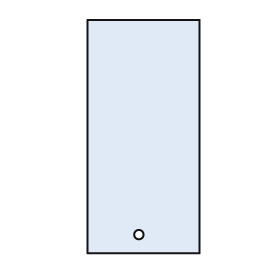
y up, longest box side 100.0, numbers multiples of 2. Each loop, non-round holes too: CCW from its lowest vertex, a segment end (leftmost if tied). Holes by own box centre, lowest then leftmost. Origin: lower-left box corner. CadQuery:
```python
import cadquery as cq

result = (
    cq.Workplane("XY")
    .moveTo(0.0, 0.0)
    .lineTo(48.0, 0.0)
    .lineTo(48.0, 100.0)
    .lineTo(0.0, 100.0)
    .close()
    .moveTo(22.0, 8.0)
    .circle(2.0)
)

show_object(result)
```